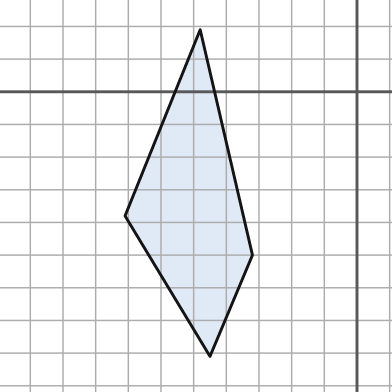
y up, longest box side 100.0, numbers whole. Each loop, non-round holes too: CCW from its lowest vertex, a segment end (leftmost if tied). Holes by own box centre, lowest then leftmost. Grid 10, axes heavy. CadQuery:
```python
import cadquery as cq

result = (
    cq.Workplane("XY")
    .moveTo(-45.0, -81.0)
    .lineTo(-32.0, -50.0)
    .lineTo(-48.0, 19.0)
    .lineTo(-71.0, -38.0)
    .close()
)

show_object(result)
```